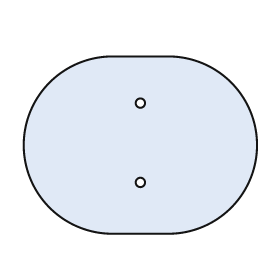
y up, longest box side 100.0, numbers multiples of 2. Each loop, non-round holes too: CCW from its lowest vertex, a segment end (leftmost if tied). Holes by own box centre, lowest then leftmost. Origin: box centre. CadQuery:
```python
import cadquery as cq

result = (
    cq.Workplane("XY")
    .moveTo(-12.0, -38.0)
    .lineTo(12.0, -38.0)
    .threePointArc((50.0, 0.0), (12.0, 38.0))
    .lineTo(-12.0, 38.0)
    .threePointArc((-50.0, 0.0), (-12.0, -38.0))
    .close()
    .moveTo(0.0, -16.0)
    .circle(2.0)
    .moveTo(0.0, 18.0)
    .circle(2.0)
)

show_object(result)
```